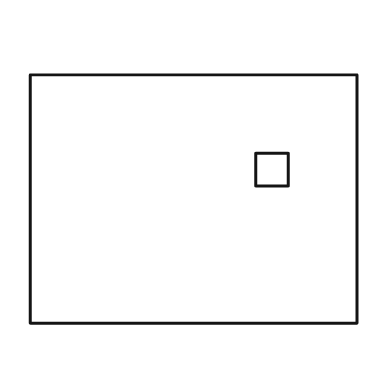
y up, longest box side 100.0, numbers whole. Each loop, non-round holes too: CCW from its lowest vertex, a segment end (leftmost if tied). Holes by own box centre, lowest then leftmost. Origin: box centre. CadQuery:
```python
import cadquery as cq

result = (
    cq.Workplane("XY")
    .moveTo(-50.0, -38.0)
    .lineTo(50.0, -38.0)
    .lineTo(50.0, 38.0)
    .lineTo(-50.0, 38.0)
    .close()
    .moveTo(19.0, 4.0)
    .lineTo(29.0, 4.0)
    .lineTo(29.0, 14.0)
    .lineTo(19.0, 14.0)
    .close()
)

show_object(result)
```